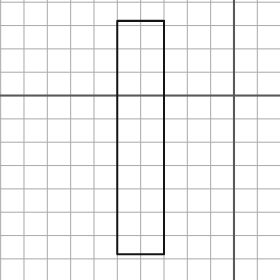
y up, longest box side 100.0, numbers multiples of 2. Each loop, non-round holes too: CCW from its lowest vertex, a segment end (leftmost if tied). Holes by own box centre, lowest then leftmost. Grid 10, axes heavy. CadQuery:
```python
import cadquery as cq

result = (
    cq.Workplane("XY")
    .moveTo(-50.0, -68.0)
    .lineTo(-30.0, -68.0)
    .lineTo(-30.0, 32.0)
    .lineTo(-50.0, 32.0)
    .close()
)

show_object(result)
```